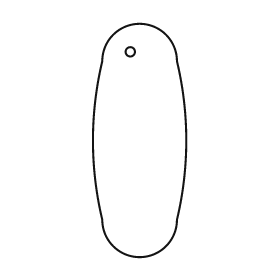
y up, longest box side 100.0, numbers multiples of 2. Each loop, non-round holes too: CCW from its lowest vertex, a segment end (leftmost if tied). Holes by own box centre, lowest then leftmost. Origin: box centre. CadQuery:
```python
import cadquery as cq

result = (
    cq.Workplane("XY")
    .moveTo(-16.0, -34.0)
    .threePointArc((0.0, -50.0), (16.0, -34.0))
    .threePointArc((20.0, 0.0), (16.0, 34.0))
    .threePointArc((0.0, 50.0), (-16.0, 34.0))
    .threePointArc((-20.0, 0.0), (-16.0, -34.0))
    .close()
    .moveTo(-4.0, 38.0)
    .circle(2.0)
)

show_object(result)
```